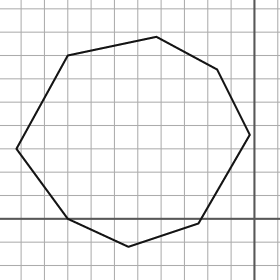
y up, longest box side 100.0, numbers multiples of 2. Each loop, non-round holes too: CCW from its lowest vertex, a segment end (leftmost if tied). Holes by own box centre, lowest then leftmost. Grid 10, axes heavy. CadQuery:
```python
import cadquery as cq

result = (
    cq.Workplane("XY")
    .moveTo(-54.0, -12.0)
    .lineTo(-24.0, -2.0)
    .lineTo(-2.0, 36.0)
    .lineTo(-16.0, 64.0)
    .lineTo(-42.0, 78.0)
    .lineTo(-80.0, 70.0)
    .lineTo(-102.0, 30.0)
    .lineTo(-80.0, 0.0)
    .close()
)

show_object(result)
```